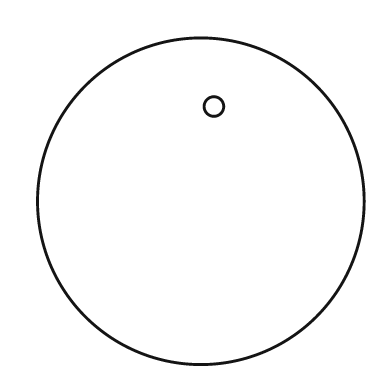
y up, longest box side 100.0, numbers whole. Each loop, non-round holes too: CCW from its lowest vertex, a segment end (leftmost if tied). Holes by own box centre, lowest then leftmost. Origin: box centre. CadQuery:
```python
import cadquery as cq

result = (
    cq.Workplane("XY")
    .moveTo(0.0, 0.0)
    .circle(50.0)
    .moveTo(4.0, 29.0)
    .circle(3.0)
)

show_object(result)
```